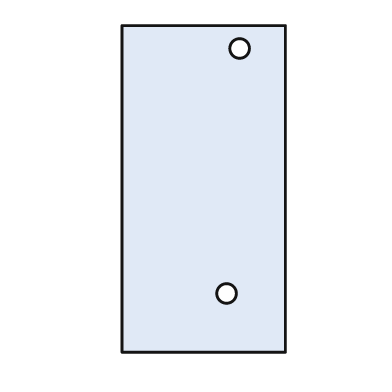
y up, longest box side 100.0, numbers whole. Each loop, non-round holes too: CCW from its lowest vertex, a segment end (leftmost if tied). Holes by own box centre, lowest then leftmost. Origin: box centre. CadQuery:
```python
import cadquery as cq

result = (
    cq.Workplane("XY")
    .moveTo(-25.0, -50.0)
    .lineTo(25.0, -50.0)
    .lineTo(25.0, 50.0)
    .lineTo(-25.0, 50.0)
    .close()
    .moveTo(7.0, -32.0)
    .circle(3.0)
    .moveTo(11.0, 43.0)
    .circle(3.0)
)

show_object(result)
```